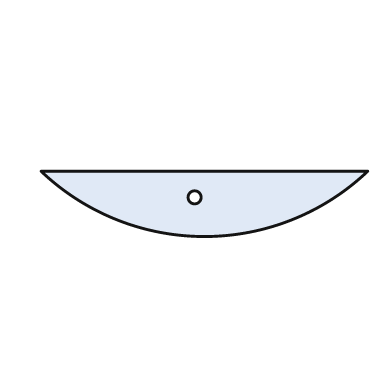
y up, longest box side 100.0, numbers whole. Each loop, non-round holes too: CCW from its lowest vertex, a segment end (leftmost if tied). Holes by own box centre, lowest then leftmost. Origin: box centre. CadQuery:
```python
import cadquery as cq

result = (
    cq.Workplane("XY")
    .moveTo(-50.0, 10.0)
    .threePointArc((0.0, -10.0), (50.0, 10.0))
    .close()
    .moveTo(-3.0, 2.0)
    .circle(2.0)
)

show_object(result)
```